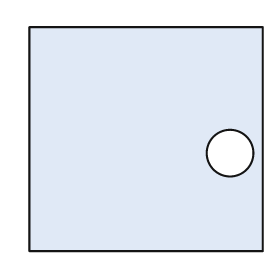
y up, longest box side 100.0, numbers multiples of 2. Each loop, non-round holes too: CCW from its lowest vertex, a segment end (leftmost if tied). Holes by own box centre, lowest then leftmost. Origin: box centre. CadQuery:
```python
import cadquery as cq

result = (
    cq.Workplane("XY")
    .moveTo(-50.0, -48.0)
    .lineTo(50.0, -48.0)
    .lineTo(50.0, 48.0)
    .lineTo(-50.0, 48.0)
    .close()
    .moveTo(36.0, -6.0)
    .circle(10.0)
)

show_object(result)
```